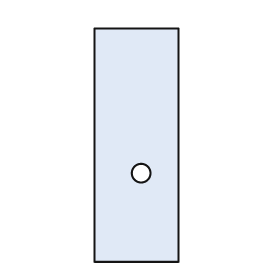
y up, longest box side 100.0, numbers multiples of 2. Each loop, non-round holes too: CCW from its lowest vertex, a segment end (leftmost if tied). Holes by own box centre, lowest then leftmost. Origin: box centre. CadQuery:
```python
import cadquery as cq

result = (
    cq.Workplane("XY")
    .moveTo(-18.0, -50.0)
    .lineTo(18.0, -50.0)
    .lineTo(18.0, 50.0)
    .lineTo(-18.0, 50.0)
    .close()
    .moveTo(2.0, -12.0)
    .circle(4.0)
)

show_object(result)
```